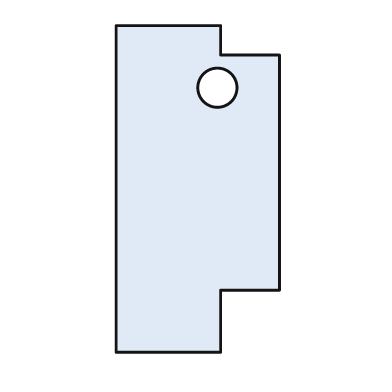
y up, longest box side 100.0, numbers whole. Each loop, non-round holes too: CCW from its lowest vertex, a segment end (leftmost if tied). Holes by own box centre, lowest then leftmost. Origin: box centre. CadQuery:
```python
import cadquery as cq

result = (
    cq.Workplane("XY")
    .moveTo(-25.0, -50.0)
    .lineTo(7.0, -50.0)
    .lineTo(7.0, -31.0)
    .lineTo(25.0, -31.0)
    .lineTo(25.0, 41.0)
    .lineTo(7.0, 41.0)
    .lineTo(7.0, 50.0)
    .lineTo(-25.0, 50.0)
    .close()
    .moveTo(6.0, 31.0)
    .circle(6.0)
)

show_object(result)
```